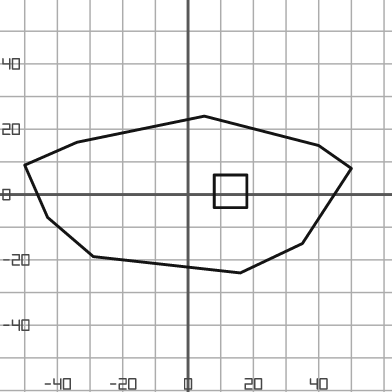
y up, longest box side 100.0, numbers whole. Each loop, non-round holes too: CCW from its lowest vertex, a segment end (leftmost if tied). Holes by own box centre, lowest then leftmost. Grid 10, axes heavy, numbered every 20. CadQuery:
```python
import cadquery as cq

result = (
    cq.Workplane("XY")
    .moveTo(16.0, -24.0)
    .lineTo(35.0, -15.0)
    .lineTo(50.0, 8.0)
    .lineTo(40.0, 15.0)
    .lineTo(5.0, 24.0)
    .lineTo(-34.0, 16.0)
    .lineTo(-50.0, 9.0)
    .lineTo(-43.0, -7.0)
    .lineTo(-29.0, -19.0)
    .close()
    .moveTo(8.0, -4.0)
    .lineTo(18.0, -4.0)
    .lineTo(18.0, 6.0)
    .lineTo(8.0, 6.0)
    .close()
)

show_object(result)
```